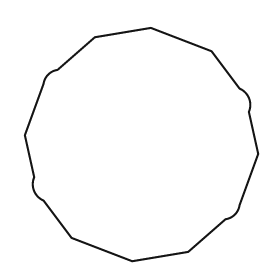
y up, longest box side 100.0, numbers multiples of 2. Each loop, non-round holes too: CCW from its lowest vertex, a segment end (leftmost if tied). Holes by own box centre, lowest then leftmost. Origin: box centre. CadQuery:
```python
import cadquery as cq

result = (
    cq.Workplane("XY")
    .moveTo(-4.0, -50.0)
    .lineTo(20.0, -46.0)
    .lineTo(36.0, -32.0)
    .threePointArc((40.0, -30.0), (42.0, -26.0))
    .lineTo(50.0, -4.0)
    .lineTo(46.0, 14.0)
    .threePointArc((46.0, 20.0), (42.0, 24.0))
    .lineTo(30.0, 40.0)
    .lineTo(4.0, 50.0)
    .lineTo(-20.0, 46.0)
    .lineTo(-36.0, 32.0)
    .threePointArc((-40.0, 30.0), (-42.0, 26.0))
    .lineTo(-50.0, 4.0)
    .lineTo(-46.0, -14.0)
    .threePointArc((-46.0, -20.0), (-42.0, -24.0))
    .lineTo(-30.0, -40.0)
    .close()
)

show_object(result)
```